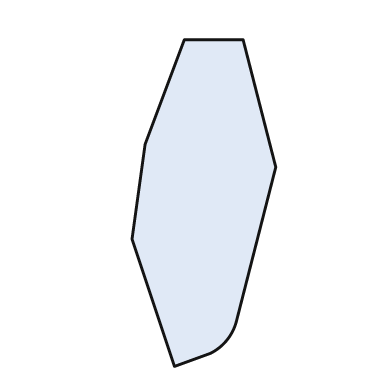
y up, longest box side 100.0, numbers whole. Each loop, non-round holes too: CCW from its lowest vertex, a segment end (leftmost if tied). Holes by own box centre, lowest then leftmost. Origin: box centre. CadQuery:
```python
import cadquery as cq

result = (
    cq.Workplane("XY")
    .moveTo(-9.0, -50.0)
    .lineTo(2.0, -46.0)
    .threePointArc((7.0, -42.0), (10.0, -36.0))
    .lineTo(22.0, 11.0)
    .lineTo(12.0, 50.0)
    .lineTo(-6.0, 50.0)
    .lineTo(-18.0, 18.0)
    .lineTo(-22.0, -11.0)
    .close()
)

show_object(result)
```